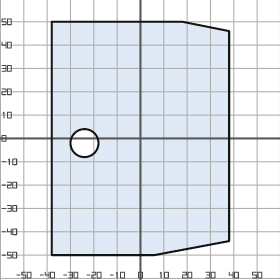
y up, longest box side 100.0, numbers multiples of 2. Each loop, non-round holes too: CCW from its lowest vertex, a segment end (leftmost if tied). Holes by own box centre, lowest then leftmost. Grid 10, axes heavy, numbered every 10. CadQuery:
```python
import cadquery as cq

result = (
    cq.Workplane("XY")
    .moveTo(-38.0, -50.0)
    .lineTo(6.0, -50.0)
    .lineTo(38.0, -44.0)
    .lineTo(38.0, 46.0)
    .lineTo(18.0, 50.0)
    .lineTo(-38.0, 50.0)
    .close()
    .moveTo(-24.0, -2.0)
    .circle(6.0)
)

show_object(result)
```